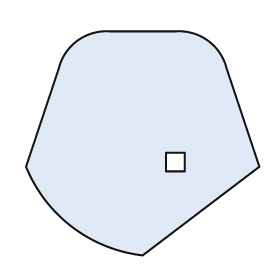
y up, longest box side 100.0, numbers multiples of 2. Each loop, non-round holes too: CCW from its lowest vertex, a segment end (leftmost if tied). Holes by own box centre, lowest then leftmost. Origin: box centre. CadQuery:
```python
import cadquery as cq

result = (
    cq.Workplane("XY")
    .moveTo(0.0, -48.0)
    .lineTo(50.0, -10.0)
    .lineTo(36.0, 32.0)
    .threePointArc((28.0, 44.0), (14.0, 48.0))
    .lineTo(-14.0, 48.0)
    .threePointArc((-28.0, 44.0), (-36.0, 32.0))
    .lineTo(-50.0, -10.0)
    .threePointArc((-30.0, -36.0), (0.0, -48.0))
    .close()
    .moveTo(10.0, -12.0)
    .lineTo(18.0, -12.0)
    .lineTo(18.0, -4.0)
    .lineTo(10.0, -4.0)
    .close()
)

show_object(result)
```